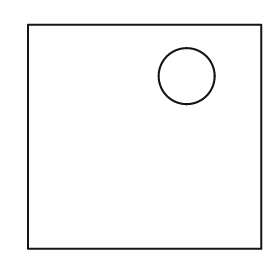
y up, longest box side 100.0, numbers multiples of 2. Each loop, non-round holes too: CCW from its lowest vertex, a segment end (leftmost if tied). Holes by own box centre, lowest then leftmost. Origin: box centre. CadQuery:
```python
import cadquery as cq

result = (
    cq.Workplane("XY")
    .moveTo(-50.0, -48.0)
    .lineTo(50.0, -48.0)
    .lineTo(50.0, 48.0)
    .lineTo(-50.0, 48.0)
    .close()
    .moveTo(18.0, 26.0)
    .circle(12.0)
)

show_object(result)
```